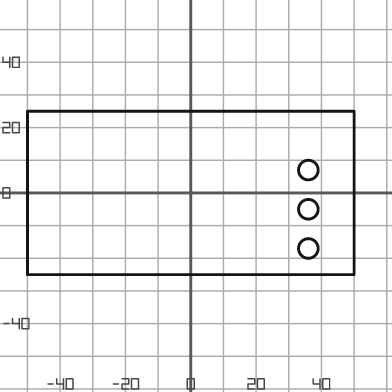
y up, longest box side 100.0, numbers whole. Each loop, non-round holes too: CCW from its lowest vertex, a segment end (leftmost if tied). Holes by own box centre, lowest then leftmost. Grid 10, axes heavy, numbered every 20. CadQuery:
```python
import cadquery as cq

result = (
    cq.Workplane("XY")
    .moveTo(-50.0, -25.0)
    .lineTo(50.0, -25.0)
    .lineTo(50.0, 25.0)
    .lineTo(-50.0, 25.0)
    .close()
    .moveTo(36.0, -17.0)
    .circle(3.0)
    .moveTo(36.0, -5.0)
    .circle(3.0)
    .moveTo(36.0, 7.0)
    .circle(3.0)
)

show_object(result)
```